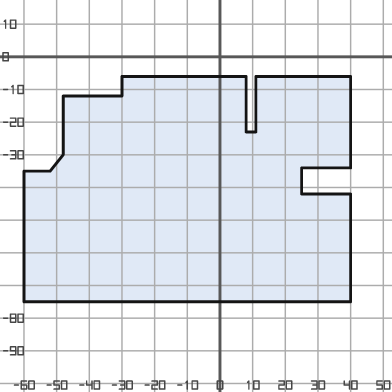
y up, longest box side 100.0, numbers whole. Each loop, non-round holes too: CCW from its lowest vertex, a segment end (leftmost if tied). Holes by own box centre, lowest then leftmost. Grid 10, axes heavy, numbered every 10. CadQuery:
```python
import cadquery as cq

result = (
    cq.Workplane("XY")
    .moveTo(-60.0, -75.0)
    .lineTo(40.0, -75.0)
    .lineTo(40.0, -42.0)
    .lineTo(25.0, -42.0)
    .lineTo(25.0, -34.0)
    .lineTo(40.0, -34.0)
    .lineTo(40.0, -6.0)
    .lineTo(11.0, -6.0)
    .lineTo(11.0, -23.0)
    .lineTo(8.0, -23.0)
    .lineTo(8.0, -6.0)
    .lineTo(-30.0, -6.0)
    .lineTo(-30.0, -12.0)
    .lineTo(-48.0, -12.0)
    .lineTo(-48.0, -30.0)
    .lineTo(-52.0, -35.0)
    .lineTo(-60.0, -35.0)
    .close()
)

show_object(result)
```